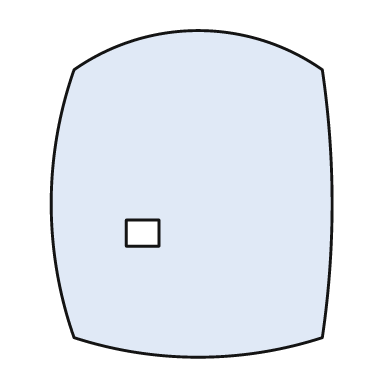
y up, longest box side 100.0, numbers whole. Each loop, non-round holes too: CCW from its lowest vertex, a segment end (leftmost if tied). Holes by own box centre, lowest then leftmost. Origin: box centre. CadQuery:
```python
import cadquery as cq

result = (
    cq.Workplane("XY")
    .moveTo(-36.0, -44.0)
    .threePointArc((2.0, -50.0), (40.0, -44.0))
    .threePointArc((43.0, -3.0), (40.0, 38.0))
    .threePointArc((2.0, 50.0), (-36.0, 38.0))
    .threePointArc((-43.0, -3.0), (-36.0, -44.0))
    .close()
    .moveTo(-20.0, -16.0)
    .lineTo(-10.0, -16.0)
    .lineTo(-10.0, -8.0)
    .lineTo(-20.0, -8.0)
    .close()
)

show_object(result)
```